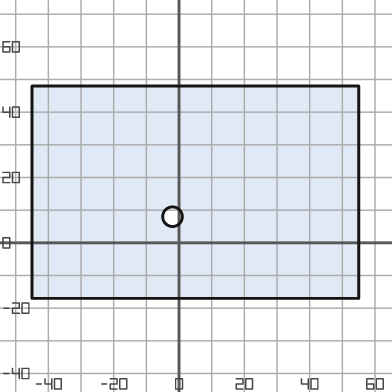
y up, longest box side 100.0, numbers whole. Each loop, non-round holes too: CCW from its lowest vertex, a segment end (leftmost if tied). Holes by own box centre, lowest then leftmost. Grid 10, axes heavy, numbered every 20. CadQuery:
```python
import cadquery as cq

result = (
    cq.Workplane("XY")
    .moveTo(-45.0, -17.0)
    .lineTo(55.0, -17.0)
    .lineTo(55.0, 48.0)
    .lineTo(-45.0, 48.0)
    .close()
    .moveTo(-2.0, 8.0)
    .circle(3.0)
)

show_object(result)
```